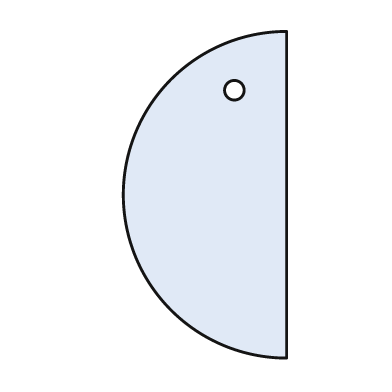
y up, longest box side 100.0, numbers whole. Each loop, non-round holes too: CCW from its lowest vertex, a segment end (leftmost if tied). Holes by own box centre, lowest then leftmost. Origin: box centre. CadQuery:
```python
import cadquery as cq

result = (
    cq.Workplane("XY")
    .moveTo(25.0, -50.0)
    .lineTo(25.0, 50.0)
    .threePointArc((-25.0, 0.0), (25.0, -50.0))
    .close()
    .moveTo(9.0, 32.0)
    .circle(3.0)
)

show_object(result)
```